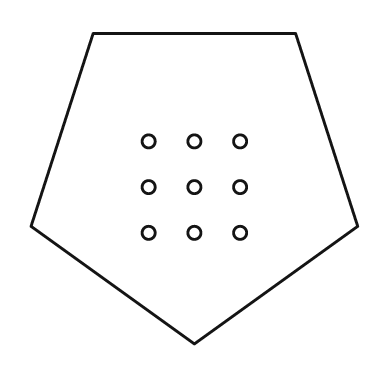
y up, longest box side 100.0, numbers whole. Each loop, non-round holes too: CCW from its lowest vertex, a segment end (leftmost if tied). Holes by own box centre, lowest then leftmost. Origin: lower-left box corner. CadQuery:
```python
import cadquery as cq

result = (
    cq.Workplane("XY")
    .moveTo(50.0, 0.0)
    .lineTo(100.0, 36.0)
    .lineTo(81.0, 95.0)
    .lineTo(19.0, 95.0)
    .lineTo(0.0, 36.0)
    .close()
    .moveTo(36.0, 34.0)
    .circle(2.0)
    .moveTo(50.0, 34.0)
    .circle(2.0)
    .moveTo(64.0, 34.0)
    .circle(2.0)
    .moveTo(36.0, 48.0)
    .circle(2.0)
    .moveTo(50.0, 48.0)
    .circle(2.0)
    .moveTo(64.0, 48.0)
    .circle(2.0)
    .moveTo(36.0, 62.0)
    .circle(2.0)
    .moveTo(50.0, 62.0)
    .circle(2.0)
    .moveTo(64.0, 62.0)
    .circle(2.0)
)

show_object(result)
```